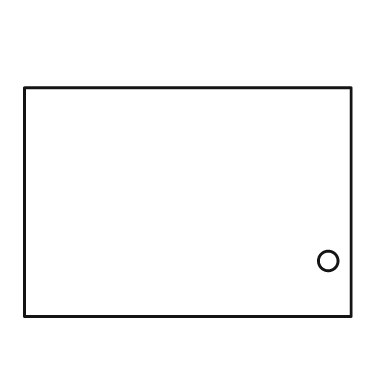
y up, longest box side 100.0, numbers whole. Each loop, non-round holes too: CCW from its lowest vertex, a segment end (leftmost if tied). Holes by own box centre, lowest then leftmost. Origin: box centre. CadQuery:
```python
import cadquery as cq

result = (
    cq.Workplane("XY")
    .moveTo(-50.0, -35.0)
    .lineTo(50.0, -35.0)
    .lineTo(50.0, 35.0)
    .lineTo(-50.0, 35.0)
    .close()
    .moveTo(43.0, -18.0)
    .circle(3.0)
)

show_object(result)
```